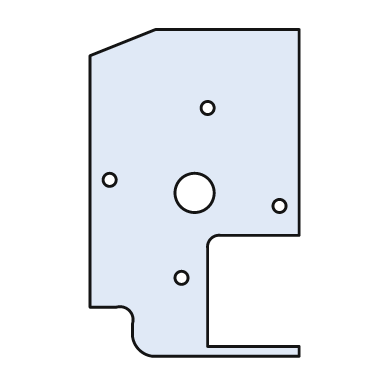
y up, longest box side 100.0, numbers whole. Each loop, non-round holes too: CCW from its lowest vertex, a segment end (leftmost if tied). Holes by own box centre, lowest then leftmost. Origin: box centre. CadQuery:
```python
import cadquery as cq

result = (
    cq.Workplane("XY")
    .moveTo(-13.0, -50.0)
    .lineTo(32.0, -50.0)
    .lineTo(32.0, -47.0)
    .lineTo(4.0, -47.0)
    .lineTo(4.0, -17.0)
    .threePointArc((5.0, -14.0), (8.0, -13.0))
    .lineTo(32.0, -13.0)
    .lineTo(32.0, 50.0)
    .lineTo(-12.0, 50.0)
    .lineTo(-32.0, 42.0)
    .lineTo(-32.0, -35.0)
    .lineTo(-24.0, -35.0)
    .threePointArc((-20.0, -36.0), (-19.0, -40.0))
    .lineTo(-19.0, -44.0)
    .threePointArc((-17.0, -48.0), (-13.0, -50.0))
    .close()
    .moveTo(-4.0, -26.0)
    .circle(2.0)
    .moveTo(26.0, -4.0)
    .circle(2.0)
    .moveTo(0.0, 0.0)
    .circle(6.0)
    .moveTo(-26.0, 4.0)
    .circle(2.0)
    .moveTo(4.0, 26.0)
    .circle(2.0)
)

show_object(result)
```